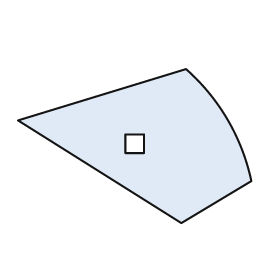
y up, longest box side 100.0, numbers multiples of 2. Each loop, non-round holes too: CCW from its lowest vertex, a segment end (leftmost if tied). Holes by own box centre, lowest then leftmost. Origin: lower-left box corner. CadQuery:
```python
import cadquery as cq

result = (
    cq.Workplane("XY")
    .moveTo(70.0, 0.0)
    .lineTo(100.0, 18.0)
    .threePointArc((90.0, 44.0), (72.0, 66.0))
    .lineTo(0.0, 44.0)
    .close()
    .moveTo(46.0, 30.0)
    .lineTo(54.0, 30.0)
    .lineTo(54.0, 38.0)
    .lineTo(46.0, 38.0)
    .close()
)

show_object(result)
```